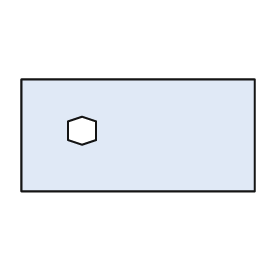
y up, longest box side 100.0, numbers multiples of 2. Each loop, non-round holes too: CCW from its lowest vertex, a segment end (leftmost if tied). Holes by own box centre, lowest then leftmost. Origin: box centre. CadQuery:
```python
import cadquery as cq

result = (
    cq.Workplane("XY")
    .moveTo(-50.0, -24.0)
    .lineTo(50.0, -24.0)
    .lineTo(50.0, 24.0)
    .lineTo(-50.0, 24.0)
    .close()
    .moveTo(-24.0, -4.0)
    .lineTo(-18.0, -2.0)
    .lineTo(-18.0, 6.0)
    .lineTo(-24.0, 8.0)
    .lineTo(-30.0, 6.0)
    .lineTo(-30.0, -2.0)
    .close()
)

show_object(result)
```